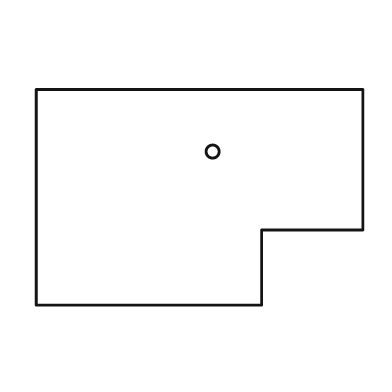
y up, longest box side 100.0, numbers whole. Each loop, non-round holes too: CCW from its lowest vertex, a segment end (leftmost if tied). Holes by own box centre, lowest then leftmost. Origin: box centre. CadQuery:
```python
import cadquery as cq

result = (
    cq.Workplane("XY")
    .moveTo(-50.0, -33.0)
    .lineTo(19.0, -33.0)
    .lineTo(19.0, -10.0)
    .lineTo(50.0, -10.0)
    .lineTo(50.0, 33.0)
    .lineTo(-50.0, 33.0)
    .close()
    .moveTo(4.0, 14.0)
    .circle(2.0)
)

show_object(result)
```